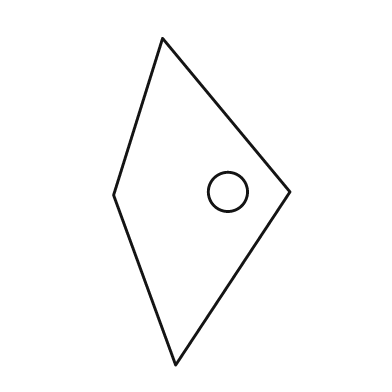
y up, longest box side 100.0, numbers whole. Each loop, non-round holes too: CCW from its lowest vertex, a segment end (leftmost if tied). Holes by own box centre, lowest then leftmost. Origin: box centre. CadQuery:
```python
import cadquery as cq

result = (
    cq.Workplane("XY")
    .moveTo(-8.0, -50.0)
    .lineTo(27.0, 3.0)
    .lineTo(-12.0, 50.0)
    .lineTo(-27.0, 2.0)
    .close()
    .moveTo(8.0, 3.0)
    .circle(6.0)
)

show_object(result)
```